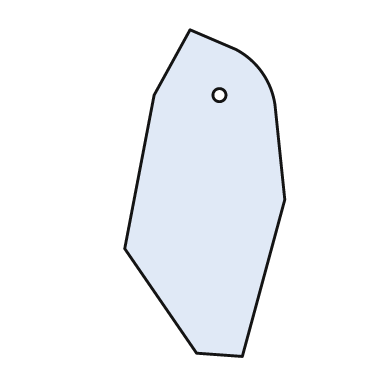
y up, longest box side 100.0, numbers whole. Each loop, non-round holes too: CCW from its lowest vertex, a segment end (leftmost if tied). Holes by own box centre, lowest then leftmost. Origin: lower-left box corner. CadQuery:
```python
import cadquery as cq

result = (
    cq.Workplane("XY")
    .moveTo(36.0, 0.0)
    .lineTo(49.0, 48.0)
    .lineTo(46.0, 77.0)
    .threePointArc((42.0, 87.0), (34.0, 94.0))
    .lineTo(20.0, 100.0)
    .lineTo(9.0, 80.0)
    .lineTo(0.0, 33.0)
    .lineTo(22.0, 1.0)
    .close()
    .moveTo(29.0, 80.0)
    .circle(2.0)
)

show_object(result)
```